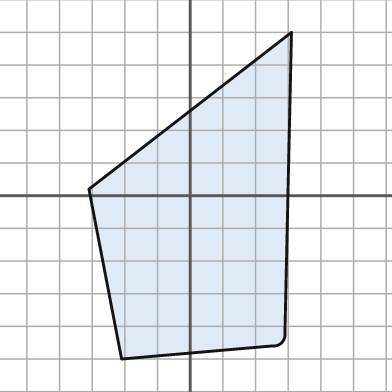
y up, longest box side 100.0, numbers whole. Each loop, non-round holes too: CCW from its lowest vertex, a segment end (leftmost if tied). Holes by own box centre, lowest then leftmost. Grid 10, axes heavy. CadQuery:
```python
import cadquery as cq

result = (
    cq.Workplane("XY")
    .moveTo(-21.0, -50.0)
    .lineTo(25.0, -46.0)
    .threePointArc((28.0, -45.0), (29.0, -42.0))
    .lineTo(31.0, 50.0)
    .lineTo(-31.0, 2.0)
    .close()
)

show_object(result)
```